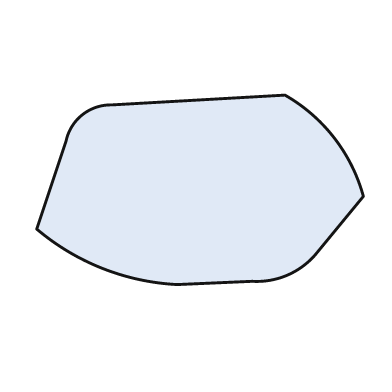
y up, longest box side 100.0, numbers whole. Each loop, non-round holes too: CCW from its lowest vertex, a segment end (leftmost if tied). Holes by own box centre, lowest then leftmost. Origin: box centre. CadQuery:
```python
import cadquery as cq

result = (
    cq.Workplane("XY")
    .moveTo(-7.0, -29.0)
    .lineTo(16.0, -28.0)
    .threePointArc((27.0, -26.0), (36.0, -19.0))
    .lineTo(50.0, -2.0)
    .threePointArc((41.0, 16.0), (26.0, 29.0))
    .lineTo(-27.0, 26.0)
    .threePointArc((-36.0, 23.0), (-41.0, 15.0))
    .lineTo(-50.0, -12.0)
    .threePointArc((-30.0, -24.0), (-7.0, -29.0))
    .close()
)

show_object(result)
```